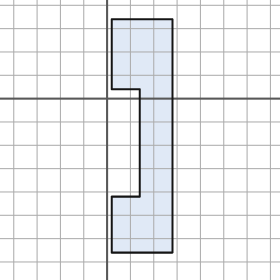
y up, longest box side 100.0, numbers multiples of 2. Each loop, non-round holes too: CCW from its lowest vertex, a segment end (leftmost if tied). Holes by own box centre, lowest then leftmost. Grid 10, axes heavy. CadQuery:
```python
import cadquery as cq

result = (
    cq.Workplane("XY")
    .moveTo(2.0, -66.0)
    .lineTo(28.0, -66.0)
    .lineTo(28.0, 34.0)
    .lineTo(2.0, 34.0)
    .lineTo(2.0, 4.0)
    .lineTo(14.0, 4.0)
    .lineTo(14.0, -42.0)
    .lineTo(2.0, -42.0)
    .close()
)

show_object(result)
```